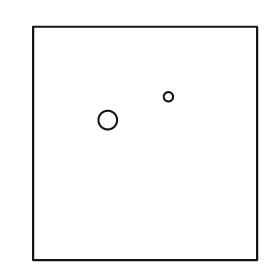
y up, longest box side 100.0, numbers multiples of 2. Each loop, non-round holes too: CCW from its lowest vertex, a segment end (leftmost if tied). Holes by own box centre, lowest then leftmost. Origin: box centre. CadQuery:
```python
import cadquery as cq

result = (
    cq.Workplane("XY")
    .moveTo(-48.0, -50.0)
    .lineTo(48.0, -50.0)
    .lineTo(48.0, 50.0)
    .lineTo(-48.0, 50.0)
    .close()
    .moveTo(-16.0, 10.0)
    .circle(4.0)
    .moveTo(10.0, 20.0)
    .circle(2.0)
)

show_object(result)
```